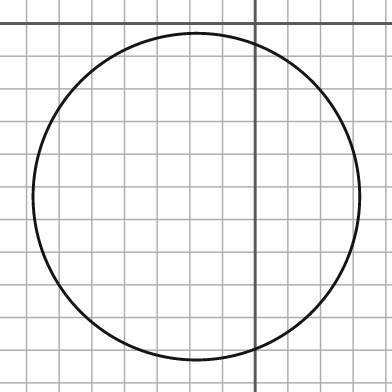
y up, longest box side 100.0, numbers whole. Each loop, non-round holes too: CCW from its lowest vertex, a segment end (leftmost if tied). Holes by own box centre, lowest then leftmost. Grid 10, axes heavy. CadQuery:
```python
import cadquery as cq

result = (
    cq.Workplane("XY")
    .moveTo(-18.0, -53.0)
    .circle(50.0)
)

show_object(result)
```